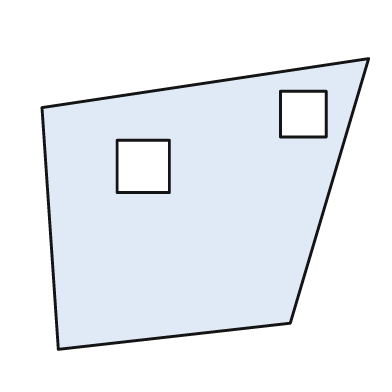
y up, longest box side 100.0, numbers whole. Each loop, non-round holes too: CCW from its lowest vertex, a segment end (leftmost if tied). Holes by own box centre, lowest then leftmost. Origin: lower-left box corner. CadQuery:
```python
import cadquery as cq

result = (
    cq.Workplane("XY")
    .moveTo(5.0, 0.0)
    .lineTo(76.0, 8.0)
    .lineTo(100.0, 89.0)
    .lineTo(0.0, 74.0)
    .close()
    .moveTo(23.0, 48.0)
    .lineTo(39.0, 48.0)
    .lineTo(39.0, 64.0)
    .lineTo(23.0, 64.0)
    .close()
    .moveTo(73.0, 65.0)
    .lineTo(87.0, 65.0)
    .lineTo(87.0, 79.0)
    .lineTo(73.0, 79.0)
    .close()
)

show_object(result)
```